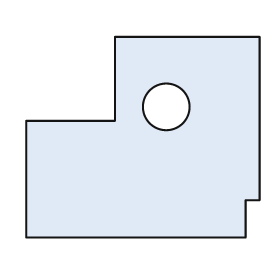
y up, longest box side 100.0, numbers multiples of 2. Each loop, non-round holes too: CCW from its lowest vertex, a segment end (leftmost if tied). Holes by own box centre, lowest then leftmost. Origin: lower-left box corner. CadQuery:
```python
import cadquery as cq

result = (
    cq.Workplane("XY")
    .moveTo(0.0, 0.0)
    .lineTo(94.0, 0.0)
    .lineTo(94.0, 16.0)
    .lineTo(100.0, 16.0)
    .lineTo(100.0, 86.0)
    .lineTo(38.0, 86.0)
    .lineTo(38.0, 50.0)
    .lineTo(0.0, 50.0)
    .close()
    .moveTo(60.0, 56.0)
    .circle(10.0)
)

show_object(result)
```